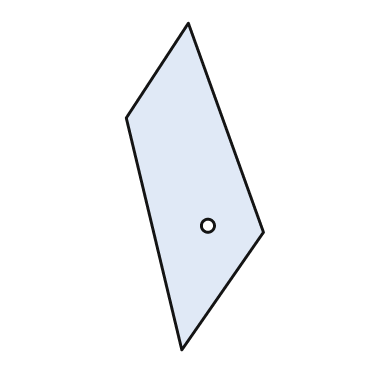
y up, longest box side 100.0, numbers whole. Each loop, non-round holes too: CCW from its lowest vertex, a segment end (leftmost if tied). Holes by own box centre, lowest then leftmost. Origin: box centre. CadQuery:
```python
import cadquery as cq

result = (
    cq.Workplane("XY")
    .moveTo(-4.0, -50.0)
    .lineTo(21.0, -14.0)
    .lineTo(-2.0, 50.0)
    .lineTo(-21.0, 21.0)
    .close()
    .moveTo(4.0, -12.0)
    .circle(2.0)
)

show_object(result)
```